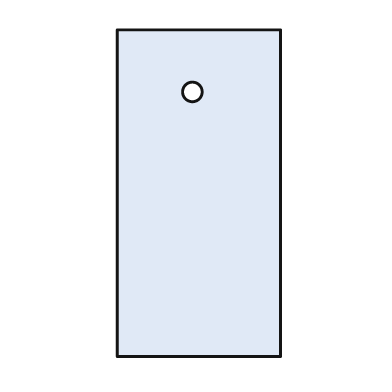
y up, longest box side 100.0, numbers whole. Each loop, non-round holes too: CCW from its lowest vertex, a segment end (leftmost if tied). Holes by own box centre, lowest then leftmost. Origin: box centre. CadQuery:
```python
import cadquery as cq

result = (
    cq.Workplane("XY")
    .moveTo(-25.0, -50.0)
    .lineTo(25.0, -50.0)
    .lineTo(25.0, 50.0)
    .lineTo(-25.0, 50.0)
    .close()
    .moveTo(-2.0, 31.0)
    .circle(3.0)
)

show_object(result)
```